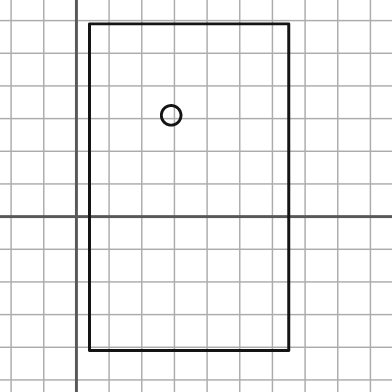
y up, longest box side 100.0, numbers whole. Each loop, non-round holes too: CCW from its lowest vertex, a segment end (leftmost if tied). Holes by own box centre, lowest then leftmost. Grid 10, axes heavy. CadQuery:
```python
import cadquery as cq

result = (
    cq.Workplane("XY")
    .moveTo(4.0, -41.0)
    .lineTo(65.0, -41.0)
    .lineTo(65.0, 59.0)
    .lineTo(4.0, 59.0)
    .close()
    .moveTo(29.0, 31.0)
    .circle(3.0)
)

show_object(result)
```